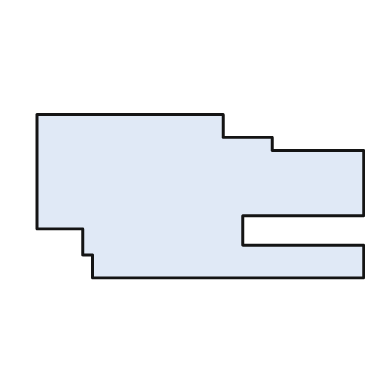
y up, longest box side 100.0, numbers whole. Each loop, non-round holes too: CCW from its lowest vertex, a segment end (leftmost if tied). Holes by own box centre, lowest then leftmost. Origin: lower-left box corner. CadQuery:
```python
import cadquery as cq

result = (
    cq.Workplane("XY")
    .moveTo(17.0, 0.0)
    .lineTo(100.0, 0.0)
    .lineTo(100.0, 10.0)
    .lineTo(63.0, 10.0)
    .lineTo(63.0, 19.0)
    .lineTo(100.0, 19.0)
    .lineTo(100.0, 39.0)
    .lineTo(72.0, 39.0)
    .lineTo(72.0, 43.0)
    .lineTo(57.0, 43.0)
    .lineTo(57.0, 50.0)
    .lineTo(0.0, 50.0)
    .lineTo(0.0, 15.0)
    .lineTo(14.0, 15.0)
    .lineTo(14.0, 7.0)
    .lineTo(17.0, 7.0)
    .close()
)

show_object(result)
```